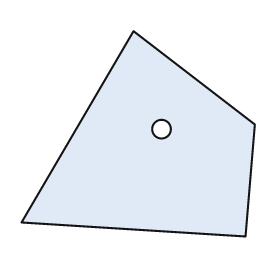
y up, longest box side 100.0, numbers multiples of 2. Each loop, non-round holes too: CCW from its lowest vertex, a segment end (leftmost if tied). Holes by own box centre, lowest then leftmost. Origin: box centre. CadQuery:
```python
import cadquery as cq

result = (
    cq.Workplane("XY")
    .moveTo(46.0, -44.0)
    .lineTo(50.0, 4.0)
    .lineTo(-2.0, 44.0)
    .lineTo(-50.0, -38.0)
    .close()
    .moveTo(10.0, 2.0)
    .circle(4.0)
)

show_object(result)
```